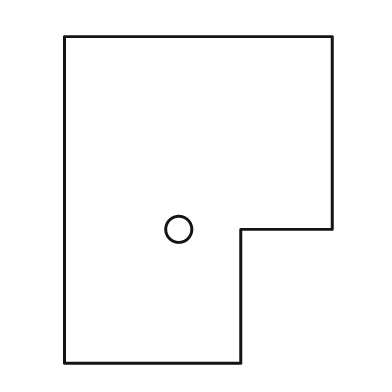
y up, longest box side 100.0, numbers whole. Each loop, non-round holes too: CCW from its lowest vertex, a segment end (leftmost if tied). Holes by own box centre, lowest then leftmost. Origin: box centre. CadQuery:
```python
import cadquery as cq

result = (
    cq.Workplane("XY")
    .moveTo(-41.0, -50.0)
    .lineTo(13.0, -50.0)
    .lineTo(13.0, -9.0)
    .lineTo(41.0, -9.0)
    .lineTo(41.0, 50.0)
    .lineTo(-41.0, 50.0)
    .close()
    .moveTo(-6.0, -9.0)
    .circle(4.0)
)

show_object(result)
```